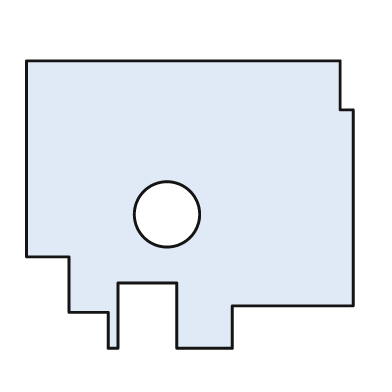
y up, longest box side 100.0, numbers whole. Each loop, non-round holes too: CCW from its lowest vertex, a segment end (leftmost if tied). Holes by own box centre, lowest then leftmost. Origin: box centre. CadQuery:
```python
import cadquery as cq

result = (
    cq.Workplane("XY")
    .moveTo(-25.0, -44.0)
    .lineTo(-22.0, -44.0)
    .lineTo(-22.0, -24.0)
    .lineTo(-4.0, -24.0)
    .lineTo(-4.0, -44.0)
    .lineTo(13.0, -44.0)
    .lineTo(13.0, -31.0)
    .lineTo(50.0, -31.0)
    .lineTo(50.0, 29.0)
    .lineTo(46.0, 29.0)
    .lineTo(46.0, 44.0)
    .lineTo(-50.0, 44.0)
    .lineTo(-50.0, -16.0)
    .lineTo(-37.0, -16.0)
    .lineTo(-37.0, -33.0)
    .lineTo(-25.0, -33.0)
    .close()
    .moveTo(-7.0, -3.0)
    .circle(10.0)
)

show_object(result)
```